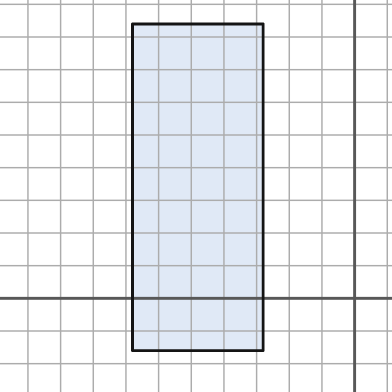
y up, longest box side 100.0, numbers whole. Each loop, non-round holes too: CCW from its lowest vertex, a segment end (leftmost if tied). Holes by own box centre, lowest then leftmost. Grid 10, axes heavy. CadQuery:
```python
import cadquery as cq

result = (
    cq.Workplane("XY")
    .moveTo(-68.0, -16.0)
    .lineTo(-28.0, -16.0)
    .lineTo(-28.0, 84.0)
    .lineTo(-68.0, 84.0)
    .close()
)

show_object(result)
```